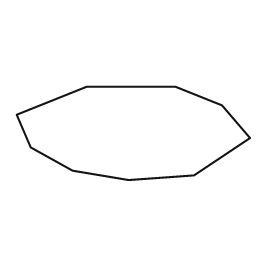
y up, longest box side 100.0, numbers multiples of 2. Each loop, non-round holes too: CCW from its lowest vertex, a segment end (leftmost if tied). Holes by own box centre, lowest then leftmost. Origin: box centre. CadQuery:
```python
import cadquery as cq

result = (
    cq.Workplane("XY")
    .moveTo(-2.0, -20.0)
    .lineTo(26.0, -18.0)
    .lineTo(50.0, -2.0)
    .lineTo(38.0, 12.0)
    .lineTo(18.0, 20.0)
    .lineTo(-20.0, 20.0)
    .lineTo(-50.0, 8.0)
    .lineTo(-44.0, -6.0)
    .lineTo(-26.0, -16.0)
    .close()
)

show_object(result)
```